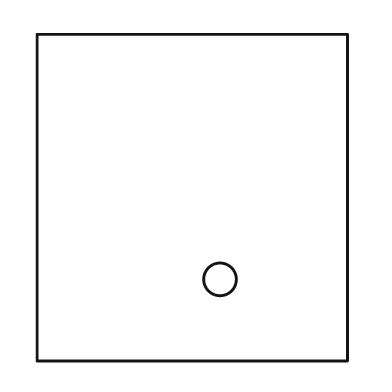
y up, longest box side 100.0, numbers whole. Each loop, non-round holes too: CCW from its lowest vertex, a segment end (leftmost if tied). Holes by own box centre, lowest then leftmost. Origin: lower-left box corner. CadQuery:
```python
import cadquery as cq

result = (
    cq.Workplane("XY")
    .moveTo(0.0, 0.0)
    .lineTo(95.0, 0.0)
    .lineTo(95.0, 100.0)
    .lineTo(0.0, 100.0)
    .close()
    .moveTo(56.0, 25.0)
    .circle(5.0)
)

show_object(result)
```